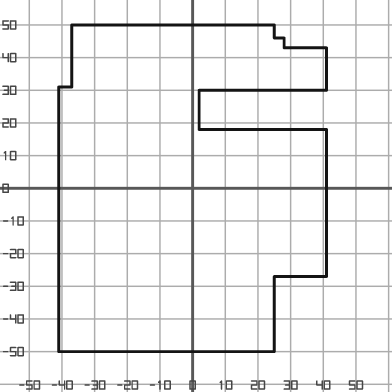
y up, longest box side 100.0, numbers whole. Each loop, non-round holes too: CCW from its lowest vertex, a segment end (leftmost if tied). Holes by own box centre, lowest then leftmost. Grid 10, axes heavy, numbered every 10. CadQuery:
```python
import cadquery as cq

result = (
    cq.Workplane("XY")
    .moveTo(-41.0, -50.0)
    .lineTo(25.0, -50.0)
    .lineTo(25.0, -27.0)
    .lineTo(41.0, -27.0)
    .lineTo(41.0, 18.0)
    .lineTo(2.0, 18.0)
    .lineTo(2.0, 30.0)
    .lineTo(41.0, 30.0)
    .lineTo(41.0, 43.0)
    .lineTo(28.0, 43.0)
    .lineTo(28.0, 46.0)
    .lineTo(25.0, 46.0)
    .lineTo(25.0, 50.0)
    .lineTo(-37.0, 50.0)
    .lineTo(-37.0, 31.0)
    .lineTo(-41.0, 31.0)
    .close()
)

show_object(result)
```